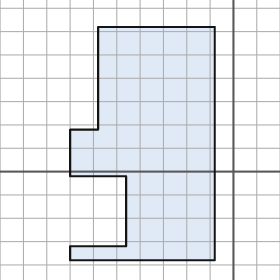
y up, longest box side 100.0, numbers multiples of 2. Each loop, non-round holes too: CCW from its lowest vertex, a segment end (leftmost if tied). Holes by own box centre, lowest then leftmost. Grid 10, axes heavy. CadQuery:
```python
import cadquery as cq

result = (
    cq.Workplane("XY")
    .moveTo(-70.0, -38.0)
    .lineTo(-8.0, -38.0)
    .lineTo(-8.0, 62.0)
    .lineTo(-58.0, 62.0)
    .lineTo(-58.0, 18.0)
    .lineTo(-70.0, 18.0)
    .lineTo(-70.0, -2.0)
    .lineTo(-46.0, -2.0)
    .lineTo(-46.0, -32.0)
    .lineTo(-70.0, -32.0)
    .close()
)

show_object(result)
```